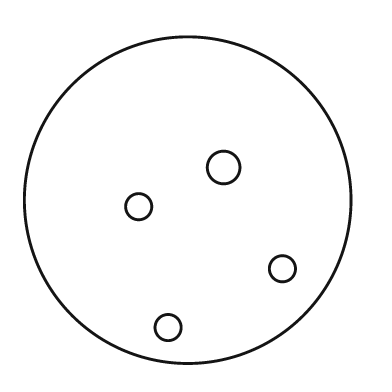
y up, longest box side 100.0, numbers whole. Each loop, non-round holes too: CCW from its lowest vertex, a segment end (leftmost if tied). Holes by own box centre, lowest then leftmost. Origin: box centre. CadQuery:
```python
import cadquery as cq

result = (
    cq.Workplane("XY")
    .moveTo(0.0, 0.0)
    .circle(50.0)
    .moveTo(-6.0, -39.0)
    .circle(4.0)
    .moveTo(29.0, -21.0)
    .circle(4.0)
    .moveTo(-15.0, -2.0)
    .circle(4.0)
    .moveTo(11.0, 10.0)
    .circle(5.0)
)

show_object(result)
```